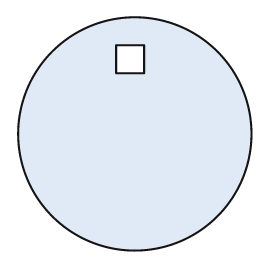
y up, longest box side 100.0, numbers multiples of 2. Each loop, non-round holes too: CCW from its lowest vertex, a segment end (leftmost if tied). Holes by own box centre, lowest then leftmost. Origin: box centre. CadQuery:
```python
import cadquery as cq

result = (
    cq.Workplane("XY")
    .moveTo(0.0, 0.0)
    .circle(50.0)
    .moveTo(-8.0, 26.0)
    .lineTo(4.0, 26.0)
    .lineTo(4.0, 38.0)
    .lineTo(-8.0, 38.0)
    .close()
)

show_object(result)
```